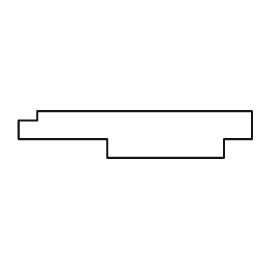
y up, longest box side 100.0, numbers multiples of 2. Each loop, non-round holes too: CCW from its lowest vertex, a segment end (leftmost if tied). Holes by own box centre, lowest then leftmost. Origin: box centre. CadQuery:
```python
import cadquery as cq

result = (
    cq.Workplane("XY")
    .moveTo(-12.0, -10.0)
    .lineTo(38.0, -10.0)
    .lineTo(38.0, -2.0)
    .lineTo(50.0, -2.0)
    .lineTo(50.0, 10.0)
    .lineTo(-42.0, 10.0)
    .lineTo(-42.0, 6.0)
    .lineTo(-50.0, 6.0)
    .lineTo(-50.0, -2.0)
    .lineTo(-12.0, -2.0)
    .close()
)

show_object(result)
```